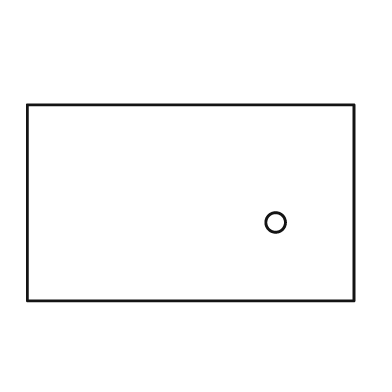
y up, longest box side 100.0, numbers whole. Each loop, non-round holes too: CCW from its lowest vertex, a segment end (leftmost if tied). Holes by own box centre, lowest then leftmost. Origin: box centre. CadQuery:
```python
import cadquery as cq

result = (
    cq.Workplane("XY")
    .moveTo(-50.0, -30.0)
    .lineTo(50.0, -30.0)
    .lineTo(50.0, 30.0)
    .lineTo(-50.0, 30.0)
    .close()
    .moveTo(26.0, -6.0)
    .circle(3.0)
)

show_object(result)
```